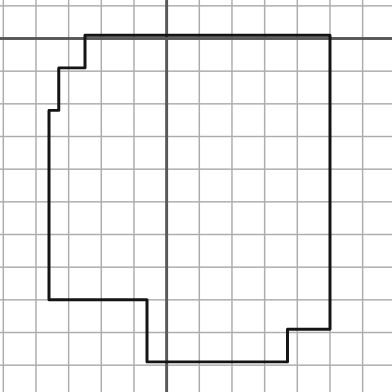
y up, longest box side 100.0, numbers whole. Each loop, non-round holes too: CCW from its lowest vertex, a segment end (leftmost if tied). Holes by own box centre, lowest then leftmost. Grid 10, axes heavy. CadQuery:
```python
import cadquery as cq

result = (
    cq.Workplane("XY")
    .moveTo(-6.0, -99.0)
    .lineTo(37.0, -99.0)
    .lineTo(37.0, -89.0)
    .lineTo(50.0, -89.0)
    .lineTo(50.0, 1.0)
    .lineTo(-25.0, 1.0)
    .lineTo(-25.0, -9.0)
    .lineTo(-33.0, -9.0)
    .lineTo(-33.0, -22.0)
    .lineTo(-36.0, -22.0)
    .lineTo(-36.0, -80.0)
    .lineTo(-6.0, -80.0)
    .close()
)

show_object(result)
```